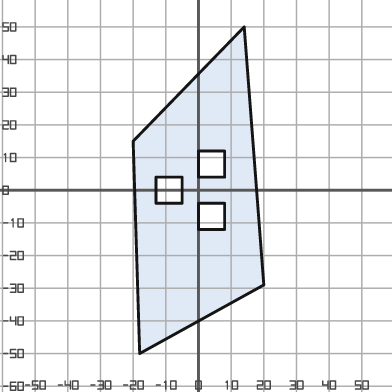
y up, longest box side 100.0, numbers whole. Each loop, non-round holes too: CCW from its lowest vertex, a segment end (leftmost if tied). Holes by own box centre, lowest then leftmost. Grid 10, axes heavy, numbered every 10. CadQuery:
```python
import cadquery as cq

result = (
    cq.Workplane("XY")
    .moveTo(-18.0, -50.0)
    .lineTo(20.0, -29.0)
    .lineTo(14.0, 50.0)
    .lineTo(-20.0, 15.0)
    .close()
    .moveTo(0.0, -12.0)
    .lineTo(8.0, -12.0)
    .lineTo(8.0, -4.0)
    .lineTo(0.0, -4.0)
    .close()
    .moveTo(-13.0, -4.0)
    .lineTo(-5.0, -4.0)
    .lineTo(-5.0, 4.0)
    .lineTo(-13.0, 4.0)
    .close()
    .moveTo(0.0, 4.0)
    .lineTo(8.0, 4.0)
    .lineTo(8.0, 12.0)
    .lineTo(0.0, 12.0)
    .close()
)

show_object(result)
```